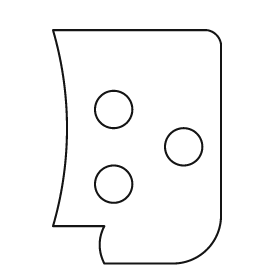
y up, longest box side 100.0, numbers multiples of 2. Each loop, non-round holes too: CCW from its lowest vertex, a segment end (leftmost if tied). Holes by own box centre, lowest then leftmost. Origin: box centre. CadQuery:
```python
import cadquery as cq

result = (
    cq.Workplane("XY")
    .moveTo(-14.0, -50.0)
    .lineTo(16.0, -50.0)
    .threePointArc((30.0, -44.0), (36.0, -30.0))
    .lineTo(36.0, 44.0)
    .threePointArc((34.0, 48.0), (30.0, 50.0))
    .lineTo(-36.0, 50.0)
    .threePointArc((-30.0, 8.0), (-36.0, -34.0))
    .lineTo(-14.0, -34.0)
    .threePointArc((-16.0, -42.0), (-14.0, -50.0))
    .close()
    .moveTo(-10.0, -16.0)
    .circle(8.0)
    .moveTo(20.0, 0.0)
    .circle(8.0)
    .moveTo(-10.0, 16.0)
    .circle(8.0)
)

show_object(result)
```